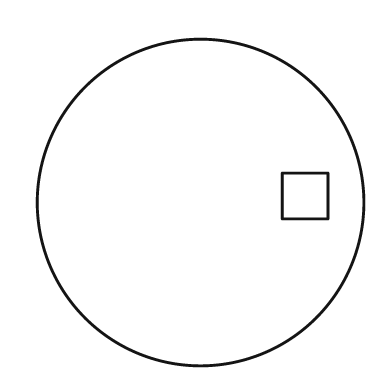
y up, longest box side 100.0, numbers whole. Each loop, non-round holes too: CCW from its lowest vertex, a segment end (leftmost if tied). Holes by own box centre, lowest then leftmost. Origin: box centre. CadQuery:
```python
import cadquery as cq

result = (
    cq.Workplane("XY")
    .moveTo(0.0, 0.0)
    .circle(50.0)
    .moveTo(25.0, -5.0)
    .lineTo(39.0, -5.0)
    .lineTo(39.0, 9.0)
    .lineTo(25.0, 9.0)
    .close()
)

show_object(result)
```